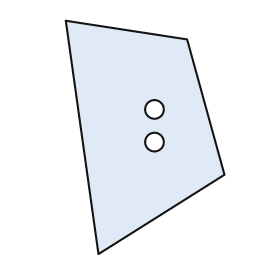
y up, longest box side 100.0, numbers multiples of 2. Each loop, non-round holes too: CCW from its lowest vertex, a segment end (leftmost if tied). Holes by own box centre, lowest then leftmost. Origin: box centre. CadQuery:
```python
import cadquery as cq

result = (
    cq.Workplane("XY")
    .moveTo(-20.0, -50.0)
    .lineTo(34.0, -16.0)
    .lineTo(18.0, 42.0)
    .lineTo(-34.0, 50.0)
    .close()
    .moveTo(4.0, -2.0)
    .circle(4.0)
    .moveTo(4.0, 12.0)
    .circle(4.0)
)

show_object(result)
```